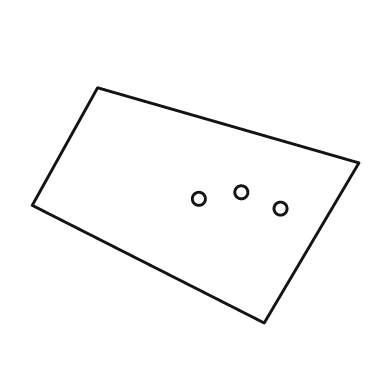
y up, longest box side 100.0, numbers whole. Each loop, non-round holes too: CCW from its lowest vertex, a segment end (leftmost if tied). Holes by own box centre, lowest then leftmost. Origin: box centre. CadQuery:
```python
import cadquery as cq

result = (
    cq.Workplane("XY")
    .moveTo(21.0, -36.0)
    .lineTo(50.0, 13.0)
    .lineTo(-30.0, 36.0)
    .lineTo(-50.0, 0.0)
    .close()
    .moveTo(26.0, -1.0)
    .circle(2.0)
    .moveTo(1.0, 2.0)
    .circle(2.0)
    .moveTo(14.0, 4.0)
    .circle(2.0)
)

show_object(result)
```